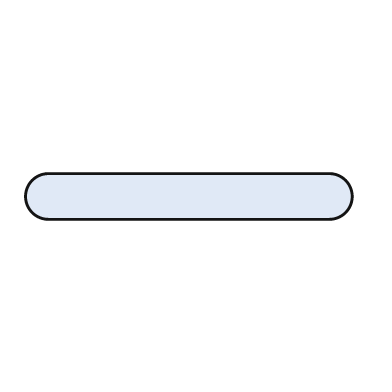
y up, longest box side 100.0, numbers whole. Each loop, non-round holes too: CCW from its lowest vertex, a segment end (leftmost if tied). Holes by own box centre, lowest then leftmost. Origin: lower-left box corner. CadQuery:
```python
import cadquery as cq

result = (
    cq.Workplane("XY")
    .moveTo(7.0, 0.0)
    .lineTo(93.0, 0.0)
    .threePointArc((100.0, 7.0), (93.0, 14.0))
    .lineTo(7.0, 14.0)
    .threePointArc((0.0, 7.0), (7.0, 0.0))
    .close()
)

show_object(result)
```